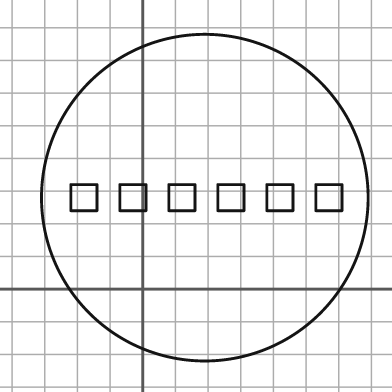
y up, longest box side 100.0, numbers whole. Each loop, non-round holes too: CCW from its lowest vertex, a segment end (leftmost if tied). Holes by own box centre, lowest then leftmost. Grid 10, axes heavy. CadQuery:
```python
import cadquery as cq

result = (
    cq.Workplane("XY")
    .moveTo(19.0, 28.0)
    .circle(50.0)
    .moveTo(-22.0, 24.0)
    .lineTo(-14.0, 24.0)
    .lineTo(-14.0, 32.0)
    .lineTo(-22.0, 32.0)
    .close()
    .moveTo(-7.0, 24.0)
    .lineTo(1.0, 24.0)
    .lineTo(1.0, 32.0)
    .lineTo(-7.0, 32.0)
    .close()
    .moveTo(8.0, 24.0)
    .lineTo(16.0, 24.0)
    .lineTo(16.0, 32.0)
    .lineTo(8.0, 32.0)
    .close()
    .moveTo(23.0, 24.0)
    .lineTo(31.0, 24.0)
    .lineTo(31.0, 32.0)
    .lineTo(23.0, 32.0)
    .close()
    .moveTo(38.0, 24.0)
    .lineTo(46.0, 24.0)
    .lineTo(46.0, 32.0)
    .lineTo(38.0, 32.0)
    .close()
    .moveTo(53.0, 24.0)
    .lineTo(61.0, 24.0)
    .lineTo(61.0, 32.0)
    .lineTo(53.0, 32.0)
    .close()
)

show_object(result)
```